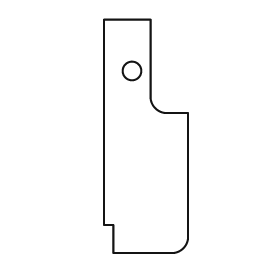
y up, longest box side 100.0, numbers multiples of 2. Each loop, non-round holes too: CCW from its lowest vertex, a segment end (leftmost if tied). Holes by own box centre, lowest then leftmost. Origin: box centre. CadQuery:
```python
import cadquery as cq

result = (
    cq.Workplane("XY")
    .moveTo(-14.0, -50.0)
    .lineTo(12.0, -50.0)
    .threePointArc((16.0, -48.0), (18.0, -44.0))
    .lineTo(18.0, 10.0)
    .lineTo(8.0, 10.0)
    .threePointArc((4.0, 12.0), (2.0, 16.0))
    .lineTo(2.0, 50.0)
    .lineTo(-18.0, 50.0)
    .lineTo(-18.0, -38.0)
    .lineTo(-14.0, -38.0)
    .close()
    .moveTo(-6.0, 28.0)
    .circle(4.0)
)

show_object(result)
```